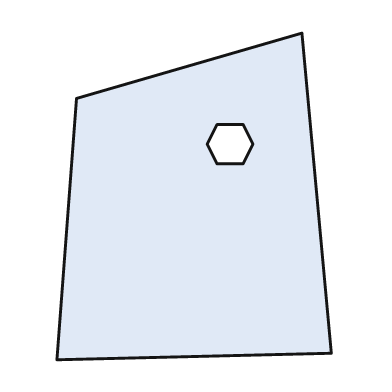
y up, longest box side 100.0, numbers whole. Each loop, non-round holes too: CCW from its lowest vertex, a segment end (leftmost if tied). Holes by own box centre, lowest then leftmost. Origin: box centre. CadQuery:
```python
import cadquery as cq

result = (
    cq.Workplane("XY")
    .moveTo(-42.0, -50.0)
    .lineTo(42.0, -48.0)
    .lineTo(33.0, 50.0)
    .lineTo(-36.0, 30.0)
    .close()
    .moveTo(7.0, 10.0)
    .lineTo(15.0, 10.0)
    .lineTo(18.0, 16.0)
    .lineTo(15.0, 22.0)
    .lineTo(7.0, 22.0)
    .lineTo(4.0, 16.0)
    .close()
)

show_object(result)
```